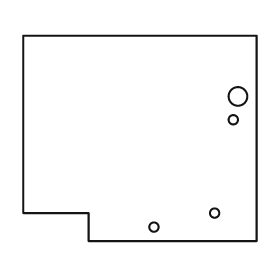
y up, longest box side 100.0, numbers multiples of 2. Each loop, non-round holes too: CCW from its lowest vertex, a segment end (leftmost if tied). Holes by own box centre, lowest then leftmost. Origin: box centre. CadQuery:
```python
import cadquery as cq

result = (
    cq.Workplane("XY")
    .moveTo(-22.0, -44.0)
    .lineTo(50.0, -44.0)
    .lineTo(50.0, 44.0)
    .lineTo(-50.0, 44.0)
    .lineTo(-50.0, -32.0)
    .lineTo(-22.0, -32.0)
    .close()
    .moveTo(6.0, -38.0)
    .circle(2.0)
    .moveTo(32.0, -32.0)
    .circle(2.0)
    .moveTo(40.0, 8.0)
    .circle(2.0)
    .moveTo(42.0, 18.0)
    .circle(4.0)
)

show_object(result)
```